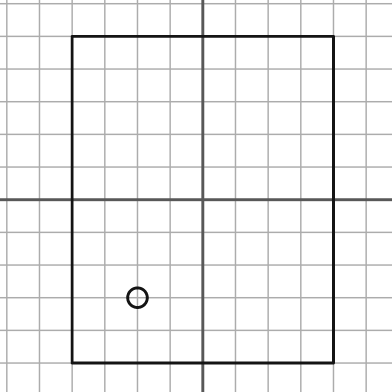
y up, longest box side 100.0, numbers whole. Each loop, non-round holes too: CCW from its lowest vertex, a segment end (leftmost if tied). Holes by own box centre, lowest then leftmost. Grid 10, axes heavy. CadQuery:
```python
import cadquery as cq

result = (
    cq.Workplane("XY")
    .moveTo(-40.0, -50.0)
    .lineTo(40.0, -50.0)
    .lineTo(40.0, 50.0)
    .lineTo(-40.0, 50.0)
    .close()
    .moveTo(-20.0, -30.0)
    .circle(3.0)
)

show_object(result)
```